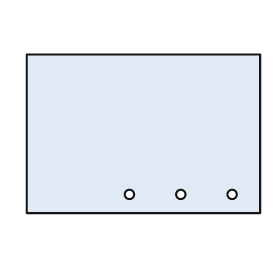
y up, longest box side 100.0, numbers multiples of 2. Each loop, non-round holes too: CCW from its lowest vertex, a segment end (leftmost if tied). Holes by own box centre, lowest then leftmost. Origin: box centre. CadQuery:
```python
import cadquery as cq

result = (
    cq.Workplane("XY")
    .moveTo(-50.0, -34.0)
    .lineTo(50.0, -34.0)
    .lineTo(50.0, 34.0)
    .lineTo(-50.0, 34.0)
    .close()
    .moveTo(-6.0, -26.0)
    .circle(2.0)
    .moveTo(16.0, -26.0)
    .circle(2.0)
    .moveTo(38.0, -26.0)
    .circle(2.0)
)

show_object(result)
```